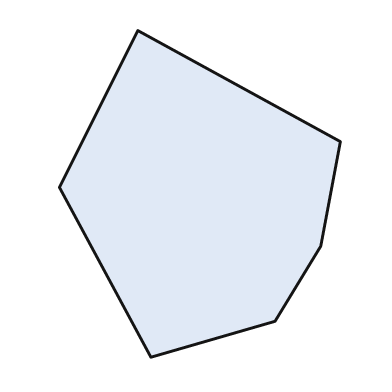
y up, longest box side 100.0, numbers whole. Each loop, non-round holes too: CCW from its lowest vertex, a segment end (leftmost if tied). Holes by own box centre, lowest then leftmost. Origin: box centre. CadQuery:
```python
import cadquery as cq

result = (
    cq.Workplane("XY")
    .moveTo(-15.0, -50.0)
    .lineTo(23.0, -39.0)
    .lineTo(37.0, -16.0)
    .lineTo(43.0, 16.0)
    .lineTo(-19.0, 50.0)
    .lineTo(-43.0, 2.0)
    .close()
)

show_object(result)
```